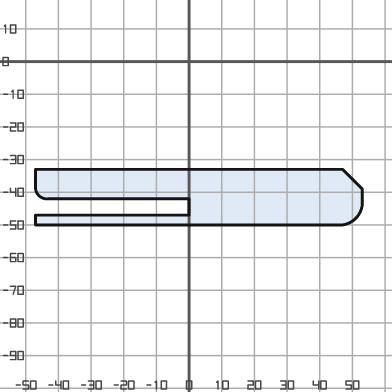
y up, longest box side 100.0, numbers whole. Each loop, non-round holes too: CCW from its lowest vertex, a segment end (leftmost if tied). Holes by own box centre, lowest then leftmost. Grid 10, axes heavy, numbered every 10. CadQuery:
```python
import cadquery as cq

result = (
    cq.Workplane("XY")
    .moveTo(-47.0, -50.0)
    .lineTo(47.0, -50.0)
    .threePointArc((51.0, -48.0), (53.0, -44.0))
    .lineTo(53.0, -39.0)
    .lineTo(47.0, -33.0)
    .lineTo(-47.0, -33.0)
    .lineTo(-47.0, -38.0)
    .threePointArc((-46.0, -41.0), (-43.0, -42.0))
    .lineTo(0.0, -42.0)
    .lineTo(0.0, -47.0)
    .lineTo(-47.0, -47.0)
    .close()
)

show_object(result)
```